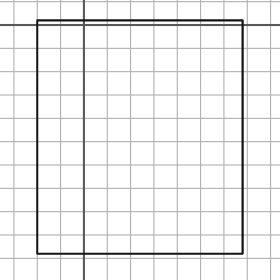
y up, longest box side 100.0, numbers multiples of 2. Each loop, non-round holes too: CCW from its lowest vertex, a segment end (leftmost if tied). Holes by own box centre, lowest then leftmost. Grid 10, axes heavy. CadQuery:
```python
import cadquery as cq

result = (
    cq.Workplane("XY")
    .moveTo(-20.0, -98.0)
    .lineTo(68.0, -98.0)
    .lineTo(68.0, 2.0)
    .lineTo(-20.0, 2.0)
    .close()
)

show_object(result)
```